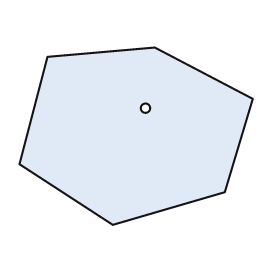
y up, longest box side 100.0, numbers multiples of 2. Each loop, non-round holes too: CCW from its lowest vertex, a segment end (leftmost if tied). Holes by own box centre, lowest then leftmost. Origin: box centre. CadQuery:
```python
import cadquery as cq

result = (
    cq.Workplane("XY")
    .moveTo(-10.0, -38.0)
    .lineTo(38.0, -24.0)
    .lineTo(50.0, 16.0)
    .lineTo(8.0, 38.0)
    .lineTo(-38.0, 34.0)
    .lineTo(-50.0, -12.0)
    .close()
    .moveTo(4.0, 12.0)
    .circle(2.0)
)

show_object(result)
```